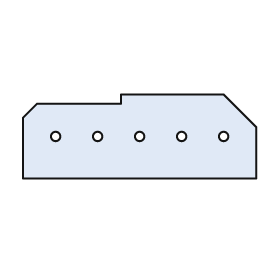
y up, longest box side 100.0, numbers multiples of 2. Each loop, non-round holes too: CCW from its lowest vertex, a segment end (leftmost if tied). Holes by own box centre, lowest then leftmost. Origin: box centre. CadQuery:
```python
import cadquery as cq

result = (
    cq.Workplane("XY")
    .moveTo(-50.0, -18.0)
    .lineTo(50.0, -18.0)
    .lineTo(50.0, 4.0)
    .lineTo(36.0, 18.0)
    .lineTo(-8.0, 18.0)
    .lineTo(-8.0, 14.0)
    .lineTo(-44.0, 14.0)
    .lineTo(-50.0, 8.0)
    .close()
    .moveTo(-36.0, 0.0)
    .circle(2.0)
    .moveTo(-18.0, 0.0)
    .circle(2.0)
    .moveTo(0.0, 0.0)
    .circle(2.0)
    .moveTo(18.0, 0.0)
    .circle(2.0)
    .moveTo(36.0, 0.0)
    .circle(2.0)
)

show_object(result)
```